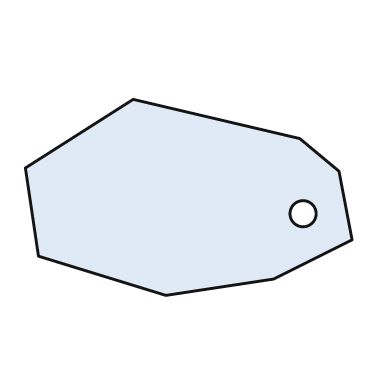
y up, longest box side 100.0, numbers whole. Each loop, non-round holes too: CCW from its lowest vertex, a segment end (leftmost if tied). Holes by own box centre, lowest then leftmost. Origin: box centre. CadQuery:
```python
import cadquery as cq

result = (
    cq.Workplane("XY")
    .moveTo(-7.0, -30.0)
    .lineTo(26.0, -25.0)
    .lineTo(50.0, -13.0)
    .lineTo(46.0, 8.0)
    .lineTo(34.0, 18.0)
    .lineTo(-17.0, 30.0)
    .lineTo(-50.0, 9.0)
    .lineTo(-46.0, -18.0)
    .close()
    .moveTo(35.0, -5.0)
    .circle(4.0)
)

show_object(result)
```